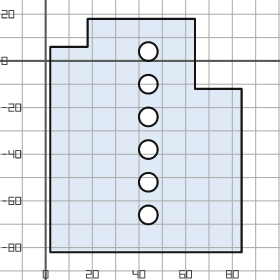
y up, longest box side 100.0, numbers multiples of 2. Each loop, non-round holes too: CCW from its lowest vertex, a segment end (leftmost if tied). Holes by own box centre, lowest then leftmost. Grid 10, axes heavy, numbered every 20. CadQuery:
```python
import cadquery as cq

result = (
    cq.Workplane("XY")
    .moveTo(2.0, -82.0)
    .lineTo(84.0, -82.0)
    .lineTo(84.0, -12.0)
    .lineTo(64.0, -12.0)
    .lineTo(64.0, 18.0)
    .lineTo(18.0, 18.0)
    .lineTo(18.0, 6.0)
    .lineTo(2.0, 6.0)
    .close()
    .moveTo(44.0, -66.0)
    .circle(4.0)
    .moveTo(44.0, -52.0)
    .circle(4.0)
    .moveTo(44.0, -38.0)
    .circle(4.0)
    .moveTo(44.0, -24.0)
    .circle(4.0)
    .moveTo(44.0, -10.0)
    .circle(4.0)
    .moveTo(44.0, 4.0)
    .circle(4.0)
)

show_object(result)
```